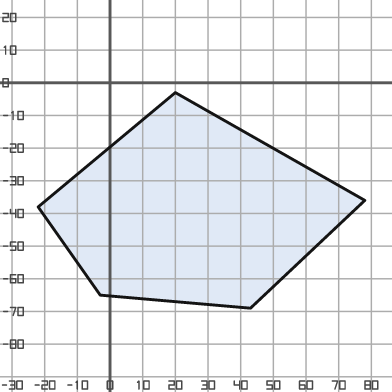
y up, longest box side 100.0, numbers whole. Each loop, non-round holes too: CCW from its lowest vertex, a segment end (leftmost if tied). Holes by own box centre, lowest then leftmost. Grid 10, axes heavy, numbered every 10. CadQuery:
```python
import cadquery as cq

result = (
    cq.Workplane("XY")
    .moveTo(43.0, -69.0)
    .lineTo(78.0, -36.0)
    .lineTo(20.0, -3.0)
    .lineTo(-22.0, -38.0)
    .lineTo(-3.0, -65.0)
    .close()
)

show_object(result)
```